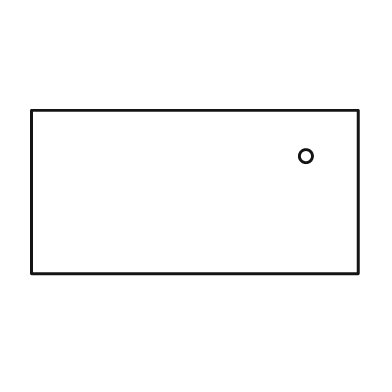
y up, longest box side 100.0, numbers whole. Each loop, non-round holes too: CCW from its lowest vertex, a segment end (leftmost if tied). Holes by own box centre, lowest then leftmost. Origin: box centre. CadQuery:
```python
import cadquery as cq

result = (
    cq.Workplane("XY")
    .moveTo(-50.0, -25.0)
    .lineTo(50.0, -25.0)
    .lineTo(50.0, 25.0)
    .lineTo(-50.0, 25.0)
    .close()
    .moveTo(34.0, 11.0)
    .circle(2.0)
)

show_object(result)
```